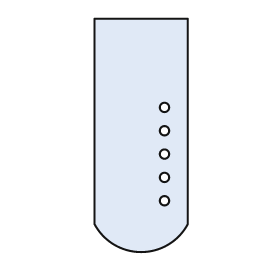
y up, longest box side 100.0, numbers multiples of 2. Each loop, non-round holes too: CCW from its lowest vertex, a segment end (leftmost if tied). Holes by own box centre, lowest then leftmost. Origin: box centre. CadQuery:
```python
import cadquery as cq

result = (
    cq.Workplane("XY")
    .moveTo(-20.0, -38.0)
    .threePointArc((0.0, -50.0), (20.0, -38.0))
    .lineTo(20.0, 50.0)
    .lineTo(-20.0, 50.0)
    .close()
    .moveTo(10.0, -28.0)
    .circle(2.0)
    .moveTo(10.0, -18.0)
    .circle(2.0)
    .moveTo(10.0, -8.0)
    .circle(2.0)
    .moveTo(10.0, 2.0)
    .circle(2.0)
    .moveTo(10.0, 12.0)
    .circle(2.0)
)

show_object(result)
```